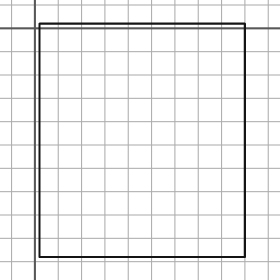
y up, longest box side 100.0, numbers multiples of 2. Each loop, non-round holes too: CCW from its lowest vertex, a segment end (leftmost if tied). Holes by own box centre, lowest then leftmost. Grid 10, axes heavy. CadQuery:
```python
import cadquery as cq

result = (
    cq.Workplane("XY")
    .moveTo(2.0, -98.0)
    .lineTo(90.0, -98.0)
    .lineTo(90.0, 2.0)
    .lineTo(2.0, 2.0)
    .close()
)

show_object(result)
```